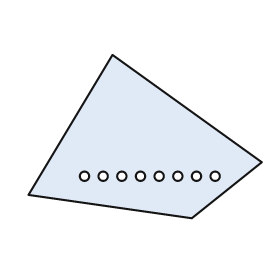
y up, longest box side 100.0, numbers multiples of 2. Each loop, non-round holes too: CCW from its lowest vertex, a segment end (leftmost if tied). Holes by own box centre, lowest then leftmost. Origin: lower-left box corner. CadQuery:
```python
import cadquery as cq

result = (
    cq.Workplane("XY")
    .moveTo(70.0, 0.0)
    .lineTo(100.0, 24.0)
    .lineTo(36.0, 70.0)
    .lineTo(0.0, 10.0)
    .close()
    .moveTo(24.0, 18.0)
    .circle(2.0)
    .moveTo(32.0, 18.0)
    .circle(2.0)
    .moveTo(40.0, 18.0)
    .circle(2.0)
    .moveTo(48.0, 18.0)
    .circle(2.0)
    .moveTo(56.0, 18.0)
    .circle(2.0)
    .moveTo(64.0, 18.0)
    .circle(2.0)
    .moveTo(72.0, 18.0)
    .circle(2.0)
    .moveTo(80.0, 18.0)
    .circle(2.0)
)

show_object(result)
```